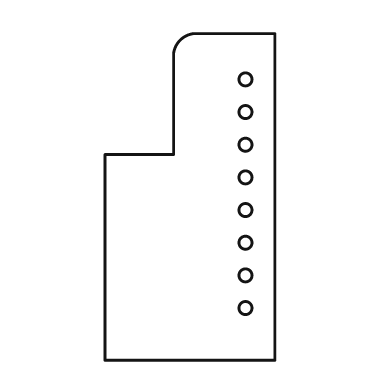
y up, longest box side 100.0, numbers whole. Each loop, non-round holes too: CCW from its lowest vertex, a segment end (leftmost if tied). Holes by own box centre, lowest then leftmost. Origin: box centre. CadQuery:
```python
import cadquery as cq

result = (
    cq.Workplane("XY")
    .moveTo(-26.0, -50.0)
    .lineTo(26.0, -50.0)
    .lineTo(26.0, 50.0)
    .lineTo(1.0, 50.0)
    .threePointArc((-3.0, 48.0), (-5.0, 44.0))
    .lineTo(-5.0, 13.0)
    .lineTo(-26.0, 13.0)
    .close()
    .moveTo(17.0, -34.0)
    .circle(2.0)
    .moveTo(17.0, -24.0)
    .circle(2.0)
    .moveTo(17.0, -14.0)
    .circle(2.0)
    .moveTo(17.0, -4.0)
    .circle(2.0)
    .moveTo(17.0, 6.0)
    .circle(2.0)
    .moveTo(17.0, 16.0)
    .circle(2.0)
    .moveTo(17.0, 26.0)
    .circle(2.0)
    .moveTo(17.0, 36.0)
    .circle(2.0)
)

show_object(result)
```